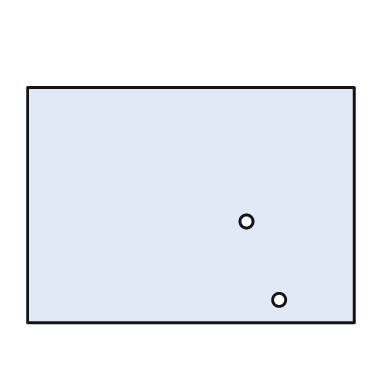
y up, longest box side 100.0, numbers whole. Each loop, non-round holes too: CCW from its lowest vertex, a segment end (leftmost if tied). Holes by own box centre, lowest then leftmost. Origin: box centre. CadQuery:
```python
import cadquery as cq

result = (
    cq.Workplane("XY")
    .moveTo(-50.0, -36.0)
    .lineTo(50.0, -36.0)
    .lineTo(50.0, 36.0)
    .lineTo(-50.0, 36.0)
    .close()
    .moveTo(27.0, -29.0)
    .circle(2.0)
    .moveTo(17.0, -5.0)
    .circle(2.0)
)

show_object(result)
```